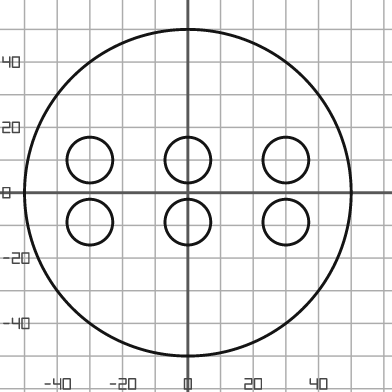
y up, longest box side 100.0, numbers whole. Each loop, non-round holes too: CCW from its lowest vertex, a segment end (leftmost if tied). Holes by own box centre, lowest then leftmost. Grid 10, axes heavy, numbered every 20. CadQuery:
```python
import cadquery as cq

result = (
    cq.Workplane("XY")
    .moveTo(0.0, 0.0)
    .circle(50.0)
    .moveTo(-30.0, -9.0)
    .circle(7.0)
    .moveTo(0.0, -9.0)
    .circle(7.0)
    .moveTo(30.0, -9.0)
    .circle(7.0)
    .moveTo(-30.0, 10.0)
    .circle(7.0)
    .moveTo(0.0, 10.0)
    .circle(7.0)
    .moveTo(30.0, 10.0)
    .circle(7.0)
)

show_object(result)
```